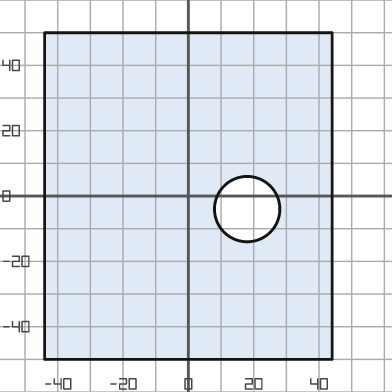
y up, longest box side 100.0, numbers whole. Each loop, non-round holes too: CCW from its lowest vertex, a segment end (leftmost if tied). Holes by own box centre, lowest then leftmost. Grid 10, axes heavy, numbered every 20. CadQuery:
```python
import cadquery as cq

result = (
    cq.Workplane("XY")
    .moveTo(-44.0, -50.0)
    .lineTo(44.0, -50.0)
    .lineTo(44.0, 50.0)
    .lineTo(-44.0, 50.0)
    .close()
    .moveTo(18.0, -4.0)
    .circle(10.0)
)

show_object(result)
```